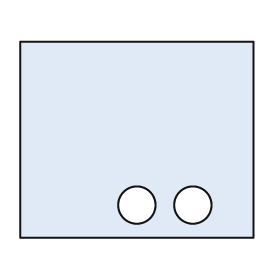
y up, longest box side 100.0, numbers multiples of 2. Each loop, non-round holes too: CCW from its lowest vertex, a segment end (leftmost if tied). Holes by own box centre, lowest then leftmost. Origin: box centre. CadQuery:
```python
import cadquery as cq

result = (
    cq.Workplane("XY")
    .moveTo(-50.0, -42.0)
    .lineTo(50.0, -42.0)
    .lineTo(50.0, 42.0)
    .lineTo(-50.0, 42.0)
    .close()
    .moveTo(0.0, -28.0)
    .circle(8.0)
    .moveTo(24.0, -28.0)
    .circle(8.0)
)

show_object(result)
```